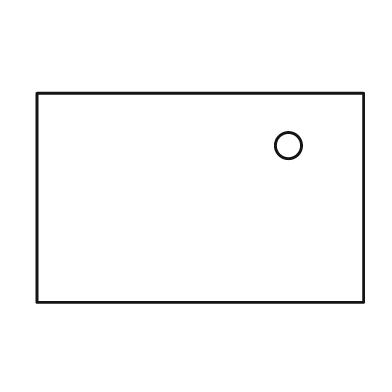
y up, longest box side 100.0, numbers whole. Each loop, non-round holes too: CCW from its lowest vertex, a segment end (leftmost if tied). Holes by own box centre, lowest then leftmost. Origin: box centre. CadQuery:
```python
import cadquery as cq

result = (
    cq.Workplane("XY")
    .moveTo(-50.0, -32.0)
    .lineTo(50.0, -32.0)
    .lineTo(50.0, 32.0)
    .lineTo(-50.0, 32.0)
    .close()
    .moveTo(27.0, 16.0)
    .circle(4.0)
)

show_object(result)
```